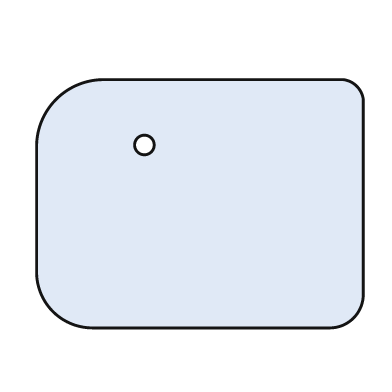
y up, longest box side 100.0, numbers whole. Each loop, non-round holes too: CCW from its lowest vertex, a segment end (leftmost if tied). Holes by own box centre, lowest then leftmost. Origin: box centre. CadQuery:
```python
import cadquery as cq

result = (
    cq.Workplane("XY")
    .moveTo(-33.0, -38.0)
    .lineTo(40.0, -38.0)
    .threePointArc((47.0, -35.0), (50.0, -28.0))
    .lineTo(50.0, 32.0)
    .threePointArc((48.0, 36.0), (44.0, 38.0))
    .lineTo(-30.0, 38.0)
    .threePointArc((-44.0, 32.0), (-50.0, 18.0))
    .lineTo(-50.0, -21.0)
    .threePointArc((-45.0, -33.0), (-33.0, -38.0))
    .close()
    .moveTo(-17.0, 18.0)
    .circle(3.0)
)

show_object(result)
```